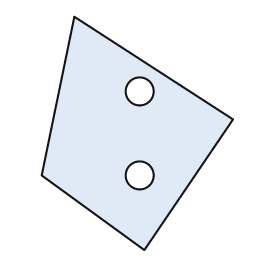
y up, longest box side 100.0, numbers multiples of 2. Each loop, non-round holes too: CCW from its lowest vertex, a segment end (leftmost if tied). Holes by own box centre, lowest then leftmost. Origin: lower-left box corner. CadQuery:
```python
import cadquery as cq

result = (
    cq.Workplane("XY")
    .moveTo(44.0, 0.0)
    .lineTo(82.0, 56.0)
    .lineTo(14.0, 100.0)
    .lineTo(0.0, 32.0)
    .close()
    .moveTo(42.0, 32.0)
    .circle(6.0)
    .moveTo(42.0, 68.0)
    .circle(6.0)
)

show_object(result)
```